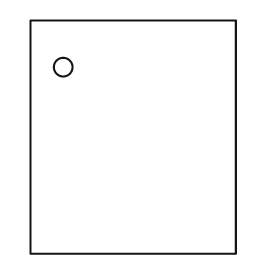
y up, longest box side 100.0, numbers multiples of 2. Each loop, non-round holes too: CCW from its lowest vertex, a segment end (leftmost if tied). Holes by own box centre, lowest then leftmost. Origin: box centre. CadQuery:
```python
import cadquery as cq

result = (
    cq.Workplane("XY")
    .moveTo(-44.0, -50.0)
    .lineTo(44.0, -50.0)
    .lineTo(44.0, 50.0)
    .lineTo(-44.0, 50.0)
    .close()
    .moveTo(-30.0, 30.0)
    .circle(4.0)
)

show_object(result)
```